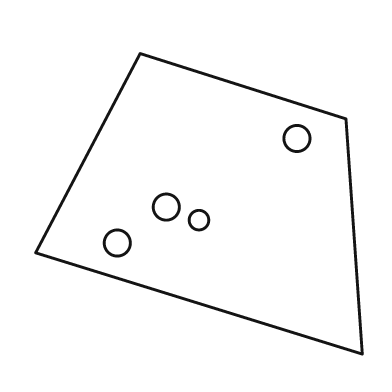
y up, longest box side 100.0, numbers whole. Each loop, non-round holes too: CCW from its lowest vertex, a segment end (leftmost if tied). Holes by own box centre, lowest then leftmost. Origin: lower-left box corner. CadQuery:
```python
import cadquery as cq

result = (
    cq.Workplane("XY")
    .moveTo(100.0, 0.0)
    .lineTo(95.0, 72.0)
    .lineTo(32.0, 92.0)
    .lineTo(0.0, 31.0)
    .close()
    .moveTo(25.0, 34.0)
    .circle(4.0)
    .moveTo(50.0, 41.0)
    .circle(3.0)
    .moveTo(40.0, 45.0)
    .circle(4.0)
    .moveTo(80.0, 66.0)
    .circle(4.0)
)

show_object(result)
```